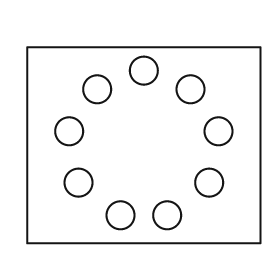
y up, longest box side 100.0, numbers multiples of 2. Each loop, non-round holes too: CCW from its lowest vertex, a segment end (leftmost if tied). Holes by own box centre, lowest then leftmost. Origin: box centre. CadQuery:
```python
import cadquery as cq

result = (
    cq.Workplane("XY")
    .moveTo(-50.0, -42.0)
    .lineTo(50.0, -42.0)
    .lineTo(50.0, 42.0)
    .lineTo(-50.0, 42.0)
    .close()
    .moveTo(-10.0, -30.0)
    .circle(6.0)
    .moveTo(10.0, -30.0)
    .circle(6.0)
    .moveTo(-28.0, -16.0)
    .circle(6.0)
    .moveTo(28.0, -16.0)
    .circle(6.0)
    .moveTo(-32.0, 6.0)
    .circle(6.0)
    .moveTo(32.0, 6.0)
    .circle(6.0)
    .moveTo(-20.0, 24.0)
    .circle(6.0)
    .moveTo(20.0, 24.0)
    .circle(6.0)
    .moveTo(0.0, 32.0)
    .circle(6.0)
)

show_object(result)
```